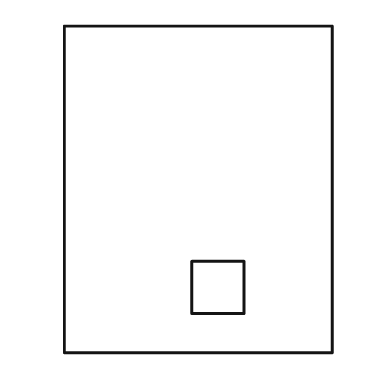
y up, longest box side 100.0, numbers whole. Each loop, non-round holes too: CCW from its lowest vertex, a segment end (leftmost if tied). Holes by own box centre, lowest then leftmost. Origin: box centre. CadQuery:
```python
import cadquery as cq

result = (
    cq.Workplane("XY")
    .moveTo(-41.0, -50.0)
    .lineTo(41.0, -50.0)
    .lineTo(41.0, 50.0)
    .lineTo(-41.0, 50.0)
    .close()
    .moveTo(-2.0, -38.0)
    .lineTo(14.0, -38.0)
    .lineTo(14.0, -22.0)
    .lineTo(-2.0, -22.0)
    .close()
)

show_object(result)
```